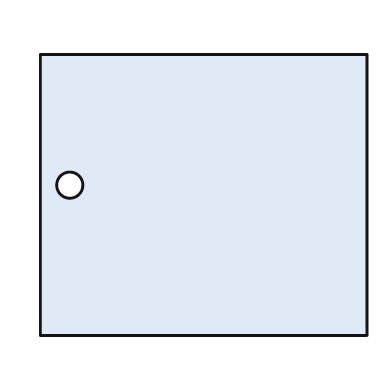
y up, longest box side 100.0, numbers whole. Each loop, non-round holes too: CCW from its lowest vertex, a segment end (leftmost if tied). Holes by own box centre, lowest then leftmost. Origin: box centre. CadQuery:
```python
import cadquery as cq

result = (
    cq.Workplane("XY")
    .moveTo(-50.0, -43.0)
    .lineTo(50.0, -43.0)
    .lineTo(50.0, 43.0)
    .lineTo(-50.0, 43.0)
    .close()
    .moveTo(-41.0, 3.0)
    .circle(4.0)
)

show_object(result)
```